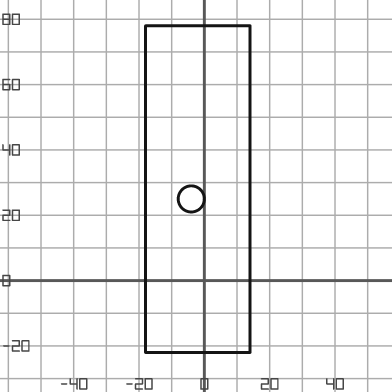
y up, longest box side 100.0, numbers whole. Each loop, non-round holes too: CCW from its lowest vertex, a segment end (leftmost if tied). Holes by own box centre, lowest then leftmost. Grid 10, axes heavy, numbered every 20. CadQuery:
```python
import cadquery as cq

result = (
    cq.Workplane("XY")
    .moveTo(-18.0, -22.0)
    .lineTo(14.0, -22.0)
    .lineTo(14.0, 78.0)
    .lineTo(-18.0, 78.0)
    .close()
    .moveTo(-4.0, 25.0)
    .circle(4.0)
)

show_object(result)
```